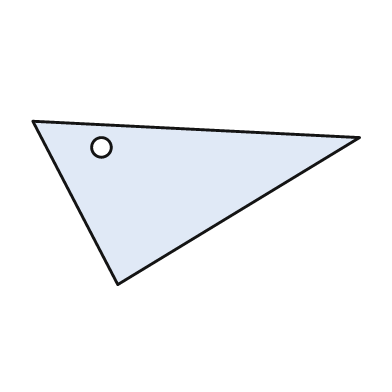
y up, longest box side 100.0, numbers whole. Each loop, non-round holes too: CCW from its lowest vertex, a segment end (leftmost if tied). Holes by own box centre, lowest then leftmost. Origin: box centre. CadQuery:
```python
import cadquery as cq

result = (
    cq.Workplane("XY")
    .moveTo(-24.0, -25.0)
    .lineTo(50.0, 20.0)
    .lineTo(-50.0, 25.0)
    .close()
    .moveTo(-29.0, 17.0)
    .circle(3.0)
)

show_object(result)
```